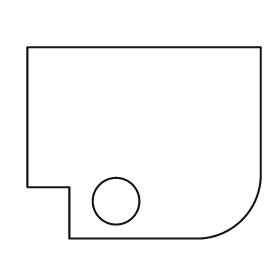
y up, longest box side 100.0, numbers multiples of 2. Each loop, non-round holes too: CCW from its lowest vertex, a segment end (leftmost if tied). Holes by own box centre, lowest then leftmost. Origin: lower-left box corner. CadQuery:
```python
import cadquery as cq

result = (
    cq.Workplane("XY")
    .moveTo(18.0, 0.0)
    .lineTo(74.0, 0.0)
    .threePointArc((92.0, 8.0), (100.0, 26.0))
    .lineTo(100.0, 82.0)
    .lineTo(0.0, 82.0)
    .lineTo(0.0, 22.0)
    .lineTo(18.0, 22.0)
    .close()
    .moveTo(38.0, 16.0)
    .circle(10.0)
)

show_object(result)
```